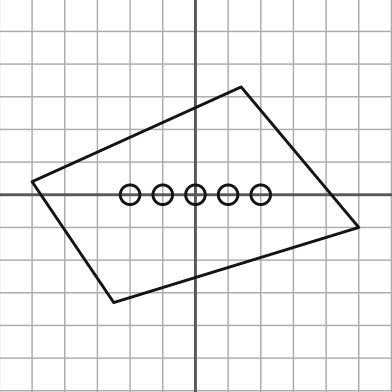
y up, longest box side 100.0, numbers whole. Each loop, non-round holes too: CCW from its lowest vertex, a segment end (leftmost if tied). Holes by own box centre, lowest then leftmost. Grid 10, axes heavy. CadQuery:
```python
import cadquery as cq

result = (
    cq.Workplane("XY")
    .moveTo(-25.0, -33.0)
    .lineTo(50.0, -10.0)
    .lineTo(14.0, 33.0)
    .lineTo(-50.0, 4.0)
    .close()
    .moveTo(-20.0, 0.0)
    .circle(3.0)
    .moveTo(-10.0, 0.0)
    .circle(3.0)
    .moveTo(0.0, 0.0)
    .circle(3.0)
    .moveTo(10.0, 0.0)
    .circle(3.0)
    .moveTo(20.0, 0.0)
    .circle(3.0)
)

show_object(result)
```